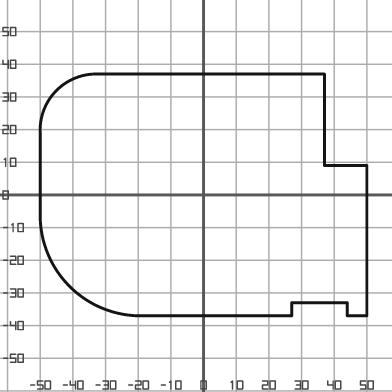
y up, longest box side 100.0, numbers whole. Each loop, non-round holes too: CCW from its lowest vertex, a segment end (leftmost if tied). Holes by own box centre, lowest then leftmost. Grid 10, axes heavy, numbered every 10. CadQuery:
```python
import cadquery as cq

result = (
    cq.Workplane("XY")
    .moveTo(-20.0, -37.0)
    .lineTo(27.0, -37.0)
    .lineTo(27.0, -33.0)
    .lineTo(44.0, -33.0)
    .lineTo(44.0, -37.0)
    .lineTo(50.0, -37.0)
    .lineTo(50.0, 9.0)
    .lineTo(37.0, 9.0)
    .lineTo(37.0, 37.0)
    .lineTo(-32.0, 37.0)
    .threePointArc((-45.0, 32.0), (-50.0, 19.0))
    .lineTo(-50.0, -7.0)
    .threePointArc((-41.0, -28.0), (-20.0, -37.0))
    .close()
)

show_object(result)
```